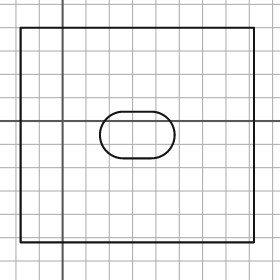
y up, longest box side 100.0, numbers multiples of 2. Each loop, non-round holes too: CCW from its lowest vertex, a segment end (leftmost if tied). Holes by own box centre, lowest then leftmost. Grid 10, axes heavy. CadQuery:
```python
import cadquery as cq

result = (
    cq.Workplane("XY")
    .moveTo(-18.0, -52.0)
    .lineTo(82.0, -52.0)
    .lineTo(82.0, 40.0)
    .lineTo(-18.0, 40.0)
    .close()
    .moveTo(26.0, -16.0)
    .lineTo(38.0, -16.0)
    .threePointArc((48.0, -6.0), (38.0, 4.0))
    .lineTo(26.0, 4.0)
    .threePointArc((16.0, -6.0), (26.0, -16.0))
    .close()
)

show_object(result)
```